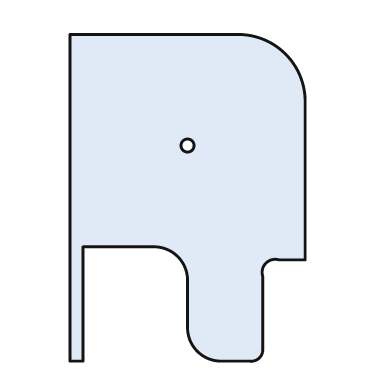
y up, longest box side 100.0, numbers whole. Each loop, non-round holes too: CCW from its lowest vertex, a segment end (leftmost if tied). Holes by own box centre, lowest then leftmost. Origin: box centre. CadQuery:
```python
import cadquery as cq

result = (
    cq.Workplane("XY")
    .moveTo(-36.0, -50.0)
    .lineTo(-32.0, -50.0)
    .lineTo(-32.0, -15.0)
    .lineTo(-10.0, -15.0)
    .threePointArc((-3.0, -18.0), (0.0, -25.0))
    .lineTo(0.0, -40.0)
    .threePointArc((3.0, -47.0), (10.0, -50.0))
    .lineTo(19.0, -50.0)
    .threePointArc((22.0, -49.0), (23.0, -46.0))
    .lineTo(23.0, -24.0)
    .threePointArc((24.0, -20.0), (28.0, -19.0))
    .lineTo(36.0, -19.0)
    .lineTo(36.0, 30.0)
    .threePointArc((30.0, 44.0), (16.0, 50.0))
    .lineTo(-36.0, 50.0)
    .close()
    .moveTo(0.0, 16.0)
    .circle(2.0)
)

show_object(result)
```